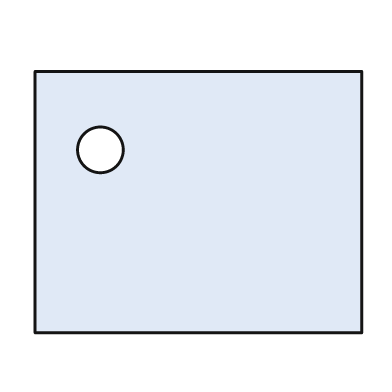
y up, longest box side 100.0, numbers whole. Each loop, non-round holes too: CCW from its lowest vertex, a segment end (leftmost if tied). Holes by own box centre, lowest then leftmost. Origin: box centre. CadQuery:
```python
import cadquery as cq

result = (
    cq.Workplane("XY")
    .moveTo(-50.0, -40.0)
    .lineTo(50.0, -40.0)
    .lineTo(50.0, 40.0)
    .lineTo(-50.0, 40.0)
    .close()
    .moveTo(-30.0, 16.0)
    .circle(7.0)
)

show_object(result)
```